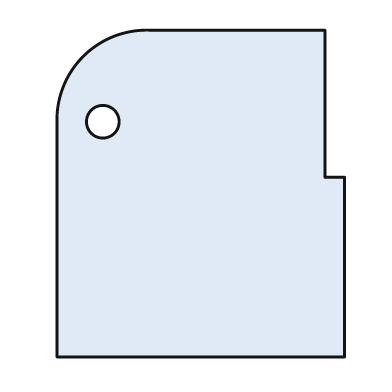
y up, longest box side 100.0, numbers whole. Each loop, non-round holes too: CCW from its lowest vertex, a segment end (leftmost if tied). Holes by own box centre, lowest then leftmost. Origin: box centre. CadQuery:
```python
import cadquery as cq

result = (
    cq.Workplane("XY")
    .moveTo(-44.0, -50.0)
    .lineTo(44.0, -50.0)
    .lineTo(44.0, 5.0)
    .lineTo(38.0, 5.0)
    .lineTo(38.0, 50.0)
    .lineTo(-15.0, 50.0)
    .threePointArc((-36.0, 42.0), (-44.0, 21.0))
    .close()
    .moveTo(-30.0, 22.0)
    .circle(5.0)
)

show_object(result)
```